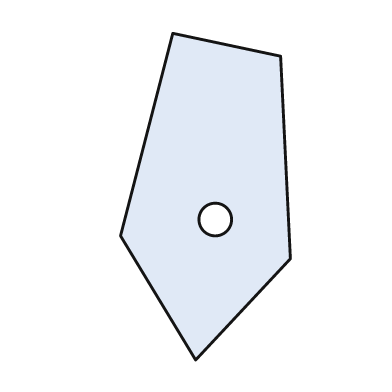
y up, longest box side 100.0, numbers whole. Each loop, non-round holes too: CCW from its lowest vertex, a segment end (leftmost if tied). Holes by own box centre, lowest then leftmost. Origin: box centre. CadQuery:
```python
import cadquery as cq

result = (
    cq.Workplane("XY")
    .moveTo(-3.0, -50.0)
    .lineTo(26.0, -19.0)
    .lineTo(23.0, 43.0)
    .lineTo(-10.0, 50.0)
    .lineTo(-26.0, -12.0)
    .close()
    .moveTo(3.0, -7.0)
    .circle(5.0)
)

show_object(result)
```